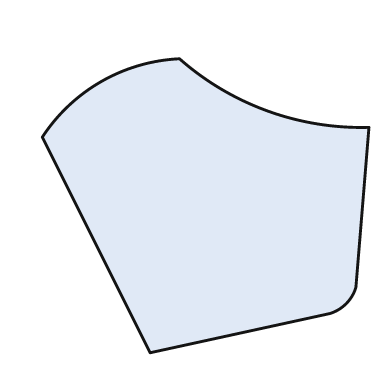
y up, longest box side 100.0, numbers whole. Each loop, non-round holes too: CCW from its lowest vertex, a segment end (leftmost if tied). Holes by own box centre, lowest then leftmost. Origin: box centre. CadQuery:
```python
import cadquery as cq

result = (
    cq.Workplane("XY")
    .moveTo(-17.0, -45.0)
    .lineTo(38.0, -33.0)
    .threePointArc((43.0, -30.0), (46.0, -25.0))
    .lineTo(50.0, 24.0)
    .threePointArc((19.0, 29.0), (-8.0, 45.0))
    .threePointArc((-32.0, 38.0), (-50.0, 21.0))
    .close()
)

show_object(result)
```